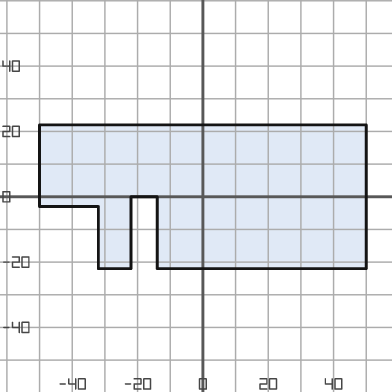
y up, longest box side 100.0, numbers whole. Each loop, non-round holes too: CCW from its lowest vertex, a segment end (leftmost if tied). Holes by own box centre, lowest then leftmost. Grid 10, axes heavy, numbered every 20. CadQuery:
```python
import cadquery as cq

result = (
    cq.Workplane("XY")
    .moveTo(-32.0, -22.0)
    .lineTo(-22.0, -22.0)
    .lineTo(-22.0, 0.0)
    .lineTo(-14.0, 0.0)
    .lineTo(-14.0, -22.0)
    .lineTo(50.0, -22.0)
    .lineTo(50.0, 22.0)
    .lineTo(-50.0, 22.0)
    .lineTo(-50.0, -3.0)
    .lineTo(-32.0, -3.0)
    .close()
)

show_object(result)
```